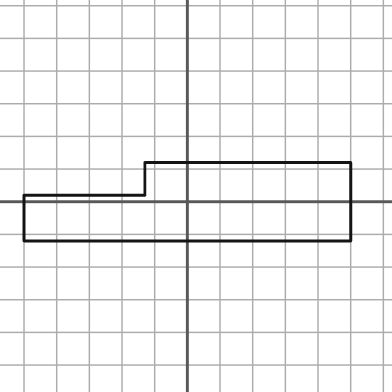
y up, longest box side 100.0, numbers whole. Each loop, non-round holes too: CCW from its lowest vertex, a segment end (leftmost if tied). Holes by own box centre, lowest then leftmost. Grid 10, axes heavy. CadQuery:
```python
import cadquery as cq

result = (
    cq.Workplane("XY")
    .moveTo(-50.0, -12.0)
    .lineTo(50.0, -12.0)
    .lineTo(50.0, 12.0)
    .lineTo(-13.0, 12.0)
    .lineTo(-13.0, 2.0)
    .lineTo(-50.0, 2.0)
    .close()
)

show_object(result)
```